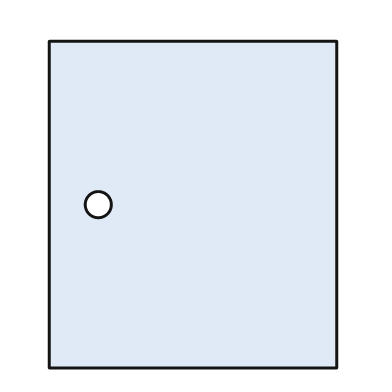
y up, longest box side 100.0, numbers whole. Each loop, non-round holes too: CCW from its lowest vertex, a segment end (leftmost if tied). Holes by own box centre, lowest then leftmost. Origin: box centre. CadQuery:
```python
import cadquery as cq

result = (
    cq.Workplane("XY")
    .moveTo(-44.0, -50.0)
    .lineTo(44.0, -50.0)
    .lineTo(44.0, 50.0)
    .lineTo(-44.0, 50.0)
    .close()
    .moveTo(-29.0, 0.0)
    .circle(4.0)
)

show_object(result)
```